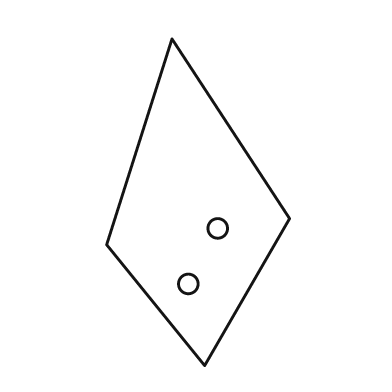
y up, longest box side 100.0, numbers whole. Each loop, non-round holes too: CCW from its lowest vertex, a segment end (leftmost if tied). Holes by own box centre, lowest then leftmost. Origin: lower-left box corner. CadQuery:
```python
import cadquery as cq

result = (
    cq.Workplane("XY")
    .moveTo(30.0, 0.0)
    .lineTo(56.0, 45.0)
    .lineTo(20.0, 100.0)
    .lineTo(0.0, 37.0)
    .close()
    .moveTo(25.0, 25.0)
    .circle(3.0)
    .moveTo(34.0, 42.0)
    .circle(3.0)
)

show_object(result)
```